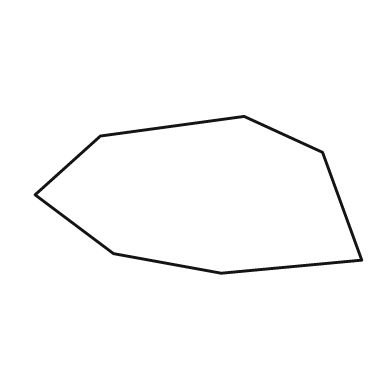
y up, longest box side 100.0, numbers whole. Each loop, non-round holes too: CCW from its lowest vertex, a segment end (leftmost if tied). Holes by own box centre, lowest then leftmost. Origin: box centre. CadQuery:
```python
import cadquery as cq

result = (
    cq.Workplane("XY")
    .moveTo(7.0, -24.0)
    .lineTo(50.0, -20.0)
    .lineTo(38.0, 13.0)
    .lineTo(14.0, 24.0)
    .lineTo(-30.0, 18.0)
    .lineTo(-50.0, 0.0)
    .lineTo(-26.0, -18.0)
    .close()
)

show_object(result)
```